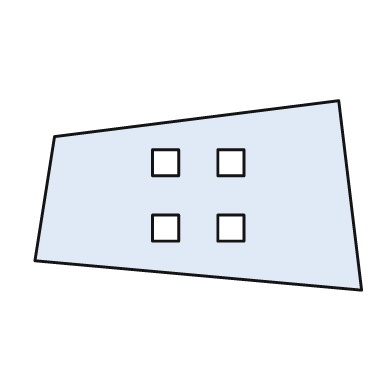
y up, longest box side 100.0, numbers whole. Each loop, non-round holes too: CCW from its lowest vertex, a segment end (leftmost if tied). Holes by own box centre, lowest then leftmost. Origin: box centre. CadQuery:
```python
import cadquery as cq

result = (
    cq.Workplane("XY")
    .moveTo(50.0, -29.0)
    .lineTo(43.0, 29.0)
    .lineTo(-44.0, 18.0)
    .lineTo(-50.0, -20.0)
    .close()
    .moveTo(-14.0, -14.0)
    .lineTo(-6.0, -14.0)
    .lineTo(-6.0, -6.0)
    .lineTo(-14.0, -6.0)
    .close()
    .moveTo(6.0, -14.0)
    .lineTo(14.0, -14.0)
    .lineTo(14.0, -6.0)
    .lineTo(6.0, -6.0)
    .close()
    .moveTo(-14.0, 6.0)
    .lineTo(-6.0, 6.0)
    .lineTo(-6.0, 14.0)
    .lineTo(-14.0, 14.0)
    .close()
    .moveTo(6.0, 6.0)
    .lineTo(14.0, 6.0)
    .lineTo(14.0, 14.0)
    .lineTo(6.0, 14.0)
    .close()
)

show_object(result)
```